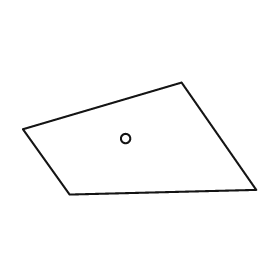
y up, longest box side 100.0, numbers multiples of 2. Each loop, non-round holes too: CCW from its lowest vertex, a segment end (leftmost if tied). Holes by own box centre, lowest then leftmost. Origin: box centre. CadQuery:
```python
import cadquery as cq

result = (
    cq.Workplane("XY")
    .moveTo(-30.0, -24.0)
    .lineTo(50.0, -22.0)
    .lineTo(18.0, 24.0)
    .lineTo(-50.0, 4.0)
    .close()
    .moveTo(-6.0, 0.0)
    .circle(2.0)
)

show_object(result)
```